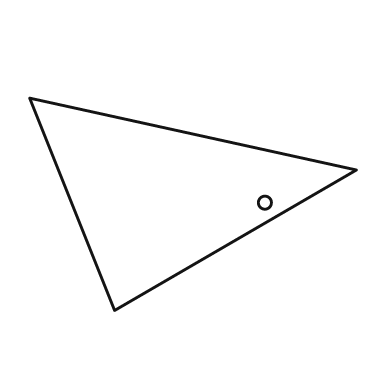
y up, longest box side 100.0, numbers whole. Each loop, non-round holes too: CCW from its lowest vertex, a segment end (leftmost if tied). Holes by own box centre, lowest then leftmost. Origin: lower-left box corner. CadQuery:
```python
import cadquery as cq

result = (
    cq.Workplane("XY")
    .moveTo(26.0, 0.0)
    .lineTo(100.0, 43.0)
    .lineTo(0.0, 65.0)
    .close()
    .moveTo(72.0, 33.0)
    .circle(2.0)
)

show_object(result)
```